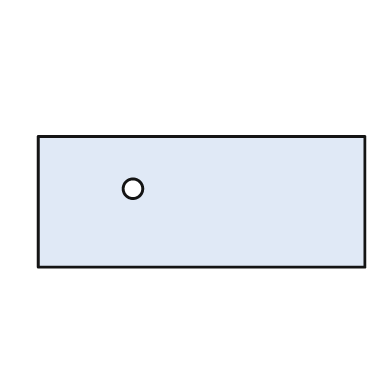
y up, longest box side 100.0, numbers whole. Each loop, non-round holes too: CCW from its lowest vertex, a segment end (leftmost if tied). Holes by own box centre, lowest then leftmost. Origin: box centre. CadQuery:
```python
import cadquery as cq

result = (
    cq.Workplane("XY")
    .moveTo(-50.0, -20.0)
    .lineTo(50.0, -20.0)
    .lineTo(50.0, 20.0)
    .lineTo(-50.0, 20.0)
    .close()
    .moveTo(-21.0, 4.0)
    .circle(3.0)
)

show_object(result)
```